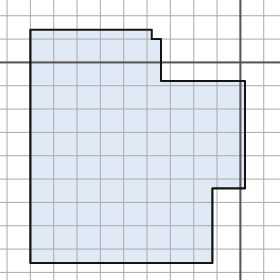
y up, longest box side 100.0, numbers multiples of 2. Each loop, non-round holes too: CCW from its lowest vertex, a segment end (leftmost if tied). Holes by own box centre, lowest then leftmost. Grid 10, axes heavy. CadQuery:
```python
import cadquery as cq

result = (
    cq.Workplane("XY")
    .moveTo(-90.0, -86.0)
    .lineTo(-12.0, -86.0)
    .lineTo(-12.0, -54.0)
    .lineTo(2.0, -54.0)
    .lineTo(2.0, -8.0)
    .lineTo(-34.0, -8.0)
    .lineTo(-34.0, 10.0)
    .lineTo(-38.0, 10.0)
    .lineTo(-38.0, 14.0)
    .lineTo(-90.0, 14.0)
    .close()
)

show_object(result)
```